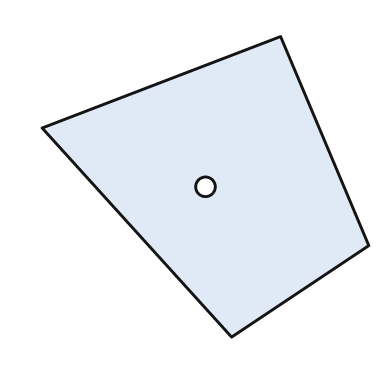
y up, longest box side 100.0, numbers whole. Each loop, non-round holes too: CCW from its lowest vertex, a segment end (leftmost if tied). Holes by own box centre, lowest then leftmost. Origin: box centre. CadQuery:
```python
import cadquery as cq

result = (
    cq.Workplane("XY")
    .moveTo(8.0, -46.0)
    .lineTo(50.0, -18.0)
    .lineTo(23.0, 46.0)
    .lineTo(-50.0, 18.0)
    .close()
    .moveTo(0.0, 0.0)
    .circle(3.0)
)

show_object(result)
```